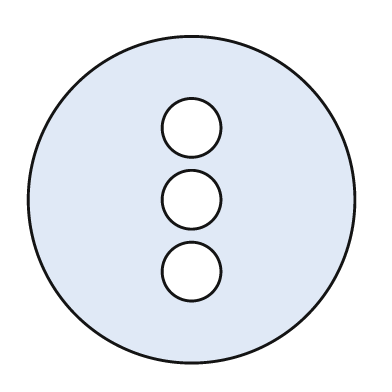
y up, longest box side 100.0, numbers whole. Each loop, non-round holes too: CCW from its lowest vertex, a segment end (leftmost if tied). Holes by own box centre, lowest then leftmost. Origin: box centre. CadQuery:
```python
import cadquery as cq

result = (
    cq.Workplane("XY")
    .moveTo(0.0, 0.0)
    .circle(50.0)
    .moveTo(0.0, -22.0)
    .circle(9.0)
    .moveTo(0.0, 0.0)
    .circle(9.0)
    .moveTo(0.0, 22.0)
    .circle(9.0)
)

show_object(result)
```